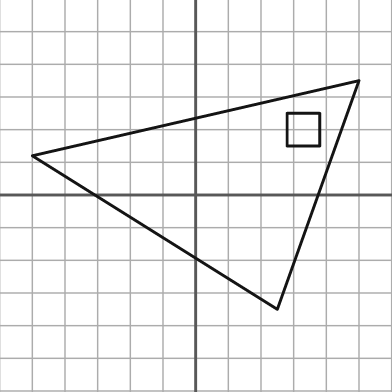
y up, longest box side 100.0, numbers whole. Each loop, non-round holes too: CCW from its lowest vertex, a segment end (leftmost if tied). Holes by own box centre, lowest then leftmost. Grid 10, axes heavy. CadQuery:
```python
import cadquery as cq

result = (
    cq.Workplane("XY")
    .moveTo(25.0, -35.0)
    .lineTo(50.0, 35.0)
    .lineTo(-50.0, 12.0)
    .close()
    .moveTo(28.0, 15.0)
    .lineTo(38.0, 15.0)
    .lineTo(38.0, 25.0)
    .lineTo(28.0, 25.0)
    .close()
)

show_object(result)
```